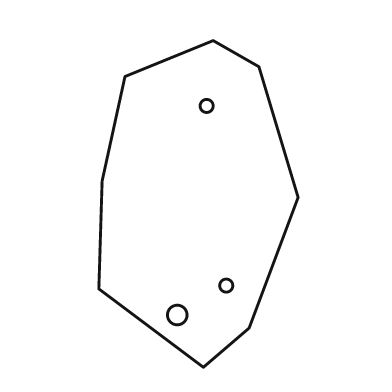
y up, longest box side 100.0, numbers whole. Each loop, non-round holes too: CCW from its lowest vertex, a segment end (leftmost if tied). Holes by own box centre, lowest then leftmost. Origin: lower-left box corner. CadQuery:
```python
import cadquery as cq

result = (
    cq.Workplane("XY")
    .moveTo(32.0, 0.0)
    .lineTo(46.0, 12.0)
    .lineTo(61.0, 52.0)
    .lineTo(49.0, 92.0)
    .lineTo(35.0, 100.0)
    .lineTo(8.0, 89.0)
    .lineTo(1.0, 57.0)
    .lineTo(0.0, 24.0)
    .close()
    .moveTo(24.0, 16.0)
    .circle(3.0)
    .moveTo(39.0, 25.0)
    .circle(2.0)
    .moveTo(33.0, 80.0)
    .circle(2.0)
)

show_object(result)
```